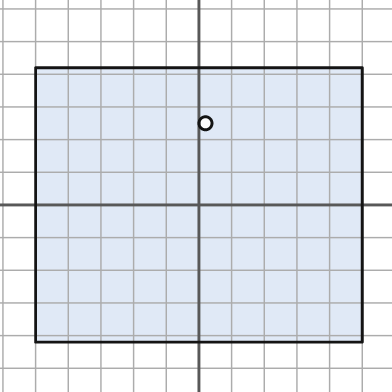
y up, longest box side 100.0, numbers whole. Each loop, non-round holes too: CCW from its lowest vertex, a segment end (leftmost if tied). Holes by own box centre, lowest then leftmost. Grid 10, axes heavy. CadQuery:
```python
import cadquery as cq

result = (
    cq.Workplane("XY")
    .moveTo(-50.0, -42.0)
    .lineTo(50.0, -42.0)
    .lineTo(50.0, 42.0)
    .lineTo(-50.0, 42.0)
    .close()
    .moveTo(2.0, 25.0)
    .circle(2.0)
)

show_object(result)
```